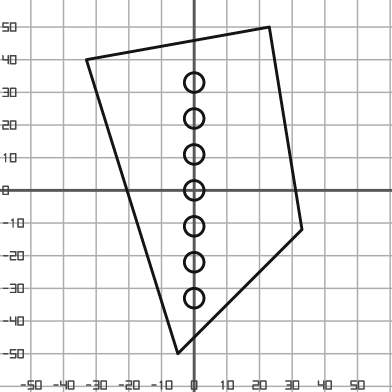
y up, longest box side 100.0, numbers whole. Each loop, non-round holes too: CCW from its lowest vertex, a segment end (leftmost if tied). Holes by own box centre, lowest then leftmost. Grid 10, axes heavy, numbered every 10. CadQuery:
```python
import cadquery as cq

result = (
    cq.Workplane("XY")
    .moveTo(-5.0, -50.0)
    .lineTo(33.0, -12.0)
    .lineTo(23.0, 50.0)
    .lineTo(-33.0, 40.0)
    .close()
    .moveTo(0.0, -33.0)
    .circle(3.0)
    .moveTo(0.0, -22.0)
    .circle(3.0)
    .moveTo(0.0, -11.0)
    .circle(3.0)
    .moveTo(0.0, 0.0)
    .circle(3.0)
    .moveTo(0.0, 11.0)
    .circle(3.0)
    .moveTo(0.0, 22.0)
    .circle(3.0)
    .moveTo(0.0, 33.0)
    .circle(3.0)
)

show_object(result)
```